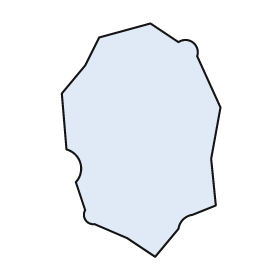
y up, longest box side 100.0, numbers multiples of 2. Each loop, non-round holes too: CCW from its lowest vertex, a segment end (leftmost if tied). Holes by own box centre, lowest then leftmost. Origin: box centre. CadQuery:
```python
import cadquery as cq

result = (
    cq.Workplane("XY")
    .moveTo(6.0, -50.0)
    .lineTo(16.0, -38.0)
    .threePointArc((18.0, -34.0), (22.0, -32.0))
    .lineTo(32.0, -28.0)
    .lineTo(30.0, -8.0)
    .lineTo(34.0, 14.0)
    .lineTo(24.0, 36.0)
    .threePointArc((22.0, 42.0), (16.0, 42.0))
    .lineTo(4.0, 50.0)
    .lineTo(-18.0, 44.0)
    .lineTo(-24.0, 32.0)
    .lineTo(-34.0, 20.0)
    .lineTo(-32.0, -4.0)
    .threePointArc((-26.0, -10.0), (-28.0, -18.0))
    .lineTo(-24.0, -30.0)
    .threePointArc((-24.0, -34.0), (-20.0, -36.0))
    .lineTo(-6.0, -42.0)
    .close()
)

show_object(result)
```